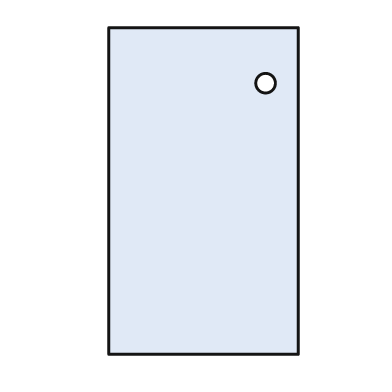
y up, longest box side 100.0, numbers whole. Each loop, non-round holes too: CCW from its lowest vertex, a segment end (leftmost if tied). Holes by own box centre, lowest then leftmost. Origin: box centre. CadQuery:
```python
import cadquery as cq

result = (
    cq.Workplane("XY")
    .moveTo(-29.0, -50.0)
    .lineTo(29.0, -50.0)
    .lineTo(29.0, 50.0)
    .lineTo(-29.0, 50.0)
    .close()
    .moveTo(19.0, 33.0)
    .circle(3.0)
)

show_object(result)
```